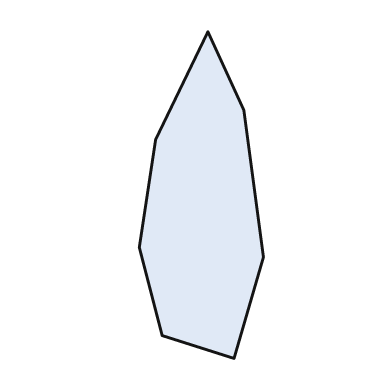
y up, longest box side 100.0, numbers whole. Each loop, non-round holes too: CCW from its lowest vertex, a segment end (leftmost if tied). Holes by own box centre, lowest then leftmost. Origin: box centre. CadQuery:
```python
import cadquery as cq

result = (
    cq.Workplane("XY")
    .moveTo(10.0, -50.0)
    .lineTo(19.0, -19.0)
    .lineTo(13.0, 26.0)
    .lineTo(2.0, 50.0)
    .lineTo(-14.0, 17.0)
    .lineTo(-19.0, -16.0)
    .lineTo(-12.0, -43.0)
    .close()
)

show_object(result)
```